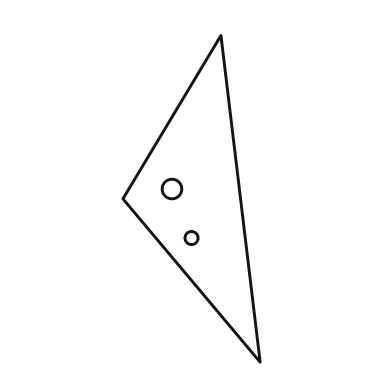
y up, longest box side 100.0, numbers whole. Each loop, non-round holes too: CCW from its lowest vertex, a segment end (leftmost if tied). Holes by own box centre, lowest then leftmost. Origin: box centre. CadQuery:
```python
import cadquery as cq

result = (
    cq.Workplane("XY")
    .moveTo(21.0, -50.0)
    .lineTo(9.0, 50.0)
    .lineTo(-21.0, 0.0)
    .close()
    .moveTo(0.0, -12.0)
    .circle(2.0)
    .moveTo(-6.0, 3.0)
    .circle(3.0)
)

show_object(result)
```